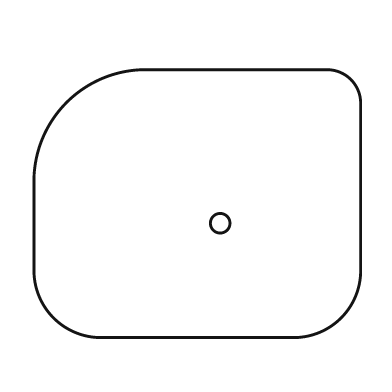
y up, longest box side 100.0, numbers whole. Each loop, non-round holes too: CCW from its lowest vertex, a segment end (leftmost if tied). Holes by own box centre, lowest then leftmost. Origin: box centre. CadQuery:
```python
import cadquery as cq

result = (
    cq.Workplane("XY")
    .moveTo(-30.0, -41.0)
    .lineTo(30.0, -41.0)
    .threePointArc((44.0, -35.0), (50.0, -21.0))
    .lineTo(50.0, 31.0)
    .threePointArc((47.0, 38.0), (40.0, 41.0))
    .lineTo(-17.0, 41.0)
    .threePointArc((-40.0, 31.0), (-50.0, 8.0))
    .lineTo(-50.0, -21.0)
    .threePointArc((-44.0, -35.0), (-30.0, -41.0))
    .close()
    .moveTo(7.0, -6.0)
    .circle(3.0)
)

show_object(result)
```